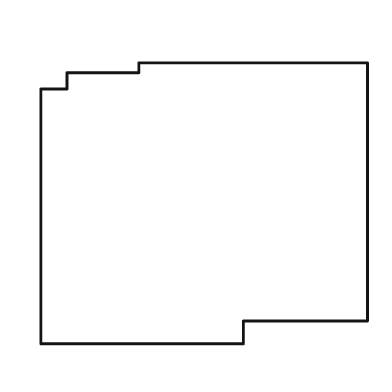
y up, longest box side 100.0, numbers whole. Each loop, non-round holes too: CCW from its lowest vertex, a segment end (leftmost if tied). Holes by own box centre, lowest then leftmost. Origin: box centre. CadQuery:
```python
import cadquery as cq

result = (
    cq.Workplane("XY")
    .moveTo(-50.0, -43.0)
    .lineTo(12.0, -43.0)
    .lineTo(12.0, -36.0)
    .lineTo(50.0, -36.0)
    .lineTo(50.0, 43.0)
    .lineTo(-20.0, 43.0)
    .lineTo(-20.0, 40.0)
    .lineTo(-42.0, 40.0)
    .lineTo(-42.0, 35.0)
    .lineTo(-50.0, 35.0)
    .close()
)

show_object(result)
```